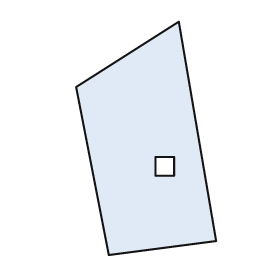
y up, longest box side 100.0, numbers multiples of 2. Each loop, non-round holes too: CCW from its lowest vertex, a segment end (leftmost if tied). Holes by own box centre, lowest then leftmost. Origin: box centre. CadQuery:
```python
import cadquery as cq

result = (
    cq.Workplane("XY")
    .moveTo(-16.0, -50.0)
    .lineTo(30.0, -44.0)
    .lineTo(14.0, 50.0)
    .lineTo(-30.0, 22.0)
    .close()
    .moveTo(4.0, -16.0)
    .lineTo(12.0, -16.0)
    .lineTo(12.0, -8.0)
    .lineTo(4.0, -8.0)
    .close()
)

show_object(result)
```